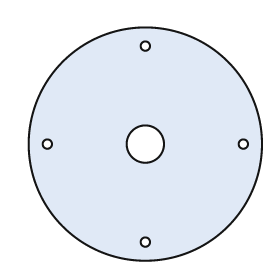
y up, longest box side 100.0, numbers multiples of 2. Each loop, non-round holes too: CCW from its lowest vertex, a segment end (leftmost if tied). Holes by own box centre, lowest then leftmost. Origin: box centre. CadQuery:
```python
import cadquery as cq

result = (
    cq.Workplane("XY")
    .moveTo(0.0, 0.0)
    .circle(50.0)
    .moveTo(0.0, -42.0)
    .circle(2.0)
    .moveTo(-42.0, 0.0)
    .circle(2.0)
    .moveTo(0.0, 0.0)
    .circle(8.0)
    .moveTo(42.0, 0.0)
    .circle(2.0)
    .moveTo(0.0, 42.0)
    .circle(2.0)
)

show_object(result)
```